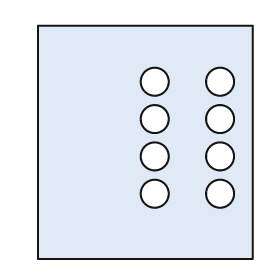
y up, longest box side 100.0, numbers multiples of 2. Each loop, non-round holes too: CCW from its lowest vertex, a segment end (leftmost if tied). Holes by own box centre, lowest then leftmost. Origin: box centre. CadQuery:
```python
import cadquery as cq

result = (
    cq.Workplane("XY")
    .moveTo(-46.0, -50.0)
    .lineTo(46.0, -50.0)
    .lineTo(46.0, 50.0)
    .lineTo(-46.0, 50.0)
    .close()
    .moveTo(4.0, -22.0)
    .circle(6.0)
    .moveTo(32.0, -22.0)
    .circle(6.0)
    .moveTo(4.0, -6.0)
    .circle(6.0)
    .moveTo(32.0, -6.0)
    .circle(6.0)
    .moveTo(4.0, 10.0)
    .circle(6.0)
    .moveTo(32.0, 10.0)
    .circle(6.0)
    .moveTo(4.0, 26.0)
    .circle(6.0)
    .moveTo(32.0, 26.0)
    .circle(6.0)
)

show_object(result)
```